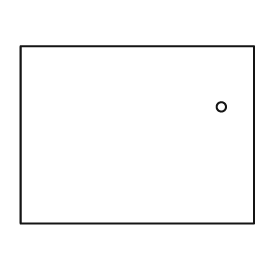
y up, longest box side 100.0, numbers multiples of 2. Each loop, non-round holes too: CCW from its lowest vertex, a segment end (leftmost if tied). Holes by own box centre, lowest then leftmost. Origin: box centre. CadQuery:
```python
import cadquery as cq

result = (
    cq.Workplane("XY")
    .moveTo(-50.0, -38.0)
    .lineTo(50.0, -38.0)
    .lineTo(50.0, 38.0)
    .lineTo(-50.0, 38.0)
    .close()
    .moveTo(36.0, 12.0)
    .circle(2.0)
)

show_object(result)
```